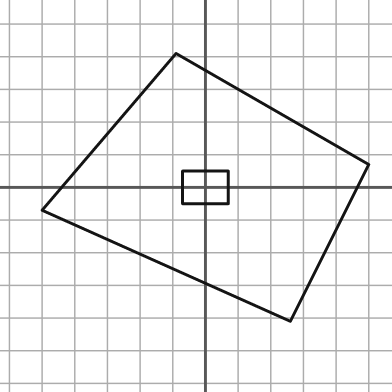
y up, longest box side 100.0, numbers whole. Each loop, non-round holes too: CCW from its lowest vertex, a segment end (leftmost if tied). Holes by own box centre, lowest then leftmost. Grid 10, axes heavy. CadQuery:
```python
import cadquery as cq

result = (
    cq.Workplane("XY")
    .moveTo(26.0, -41.0)
    .lineTo(50.0, 7.0)
    .lineTo(-9.0, 41.0)
    .lineTo(-50.0, -7.0)
    .close()
    .moveTo(-7.0, -5.0)
    .lineTo(7.0, -5.0)
    .lineTo(7.0, 5.0)
    .lineTo(-7.0, 5.0)
    .close()
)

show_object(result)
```